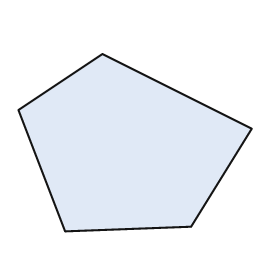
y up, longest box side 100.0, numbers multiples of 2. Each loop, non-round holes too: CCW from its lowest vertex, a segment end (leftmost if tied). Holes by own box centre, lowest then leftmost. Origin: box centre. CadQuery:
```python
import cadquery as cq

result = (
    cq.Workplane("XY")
    .moveTo(-30.0, -38.0)
    .lineTo(24.0, -36.0)
    .lineTo(50.0, 6.0)
    .lineTo(-14.0, 38.0)
    .lineTo(-50.0, 14.0)
    .close()
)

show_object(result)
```